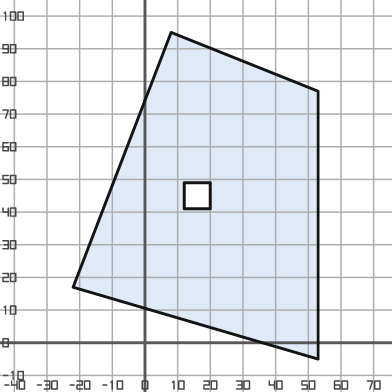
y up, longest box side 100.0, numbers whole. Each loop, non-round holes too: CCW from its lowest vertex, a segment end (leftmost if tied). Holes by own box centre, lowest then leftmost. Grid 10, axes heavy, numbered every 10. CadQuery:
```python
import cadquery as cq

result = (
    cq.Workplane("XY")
    .moveTo(53.0, -5.0)
    .lineTo(53.0, 77.0)
    .lineTo(8.0, 95.0)
    .lineTo(-22.0, 17.0)
    .close()
    .moveTo(12.0, 41.0)
    .lineTo(20.0, 41.0)
    .lineTo(20.0, 49.0)
    .lineTo(12.0, 49.0)
    .close()
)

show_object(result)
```